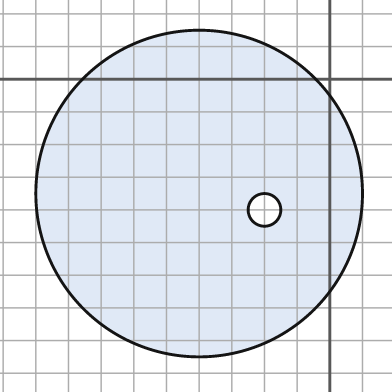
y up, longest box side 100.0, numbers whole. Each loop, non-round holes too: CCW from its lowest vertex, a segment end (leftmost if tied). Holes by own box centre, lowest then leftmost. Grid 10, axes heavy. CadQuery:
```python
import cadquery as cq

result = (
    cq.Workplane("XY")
    .moveTo(-40.0, -35.0)
    .circle(50.0)
    .moveTo(-20.0, -40.0)
    .circle(5.0)
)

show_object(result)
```